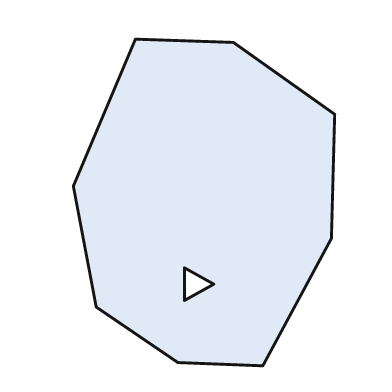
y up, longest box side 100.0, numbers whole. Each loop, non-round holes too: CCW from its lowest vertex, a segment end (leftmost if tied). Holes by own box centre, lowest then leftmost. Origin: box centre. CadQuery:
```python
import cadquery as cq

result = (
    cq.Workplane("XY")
    .moveTo(18.0, -50.0)
    .lineTo(39.0, -11.0)
    .lineTo(40.0, 27.0)
    .lineTo(9.0, 49.0)
    .lineTo(-21.0, 50.0)
    .lineTo(-40.0, 5.0)
    .lineTo(-33.0, -32.0)
    .lineTo(-8.0, -49.0)
    .close()
    .moveTo(-6.0, -30.0)
    .lineTo(3.0, -25.0)
    .lineTo(-6.0, -20.0)
    .close()
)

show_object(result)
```